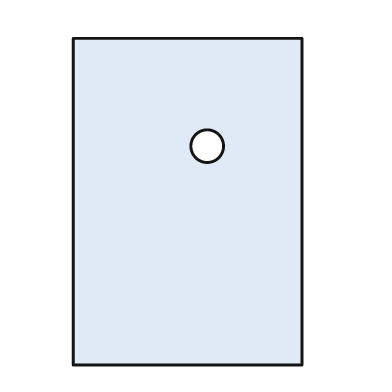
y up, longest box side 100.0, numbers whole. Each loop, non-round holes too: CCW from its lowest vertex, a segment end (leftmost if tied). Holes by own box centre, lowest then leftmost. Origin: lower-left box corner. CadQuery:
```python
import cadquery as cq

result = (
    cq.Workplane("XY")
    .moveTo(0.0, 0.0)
    .lineTo(70.0, 0.0)
    .lineTo(70.0, 100.0)
    .lineTo(0.0, 100.0)
    .close()
    .moveTo(41.0, 67.0)
    .circle(5.0)
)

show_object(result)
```